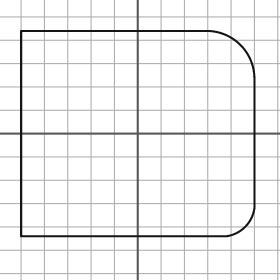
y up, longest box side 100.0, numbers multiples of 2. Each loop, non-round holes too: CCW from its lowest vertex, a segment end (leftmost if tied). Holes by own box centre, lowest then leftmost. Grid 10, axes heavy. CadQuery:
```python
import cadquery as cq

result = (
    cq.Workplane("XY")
    .moveTo(-50.0, -44.0)
    .lineTo(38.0, -44.0)
    .threePointArc((46.0, -40.0), (50.0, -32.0))
    .lineTo(50.0, 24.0)
    .threePointArc((44.0, 38.0), (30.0, 44.0))
    .lineTo(-50.0, 44.0)
    .close()
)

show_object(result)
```